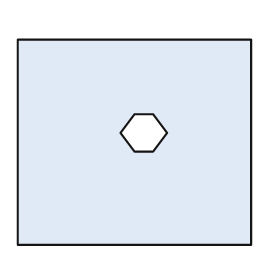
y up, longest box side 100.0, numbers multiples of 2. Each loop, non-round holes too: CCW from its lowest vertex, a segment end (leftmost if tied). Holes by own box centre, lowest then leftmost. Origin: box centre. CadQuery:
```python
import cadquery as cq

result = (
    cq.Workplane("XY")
    .moveTo(-50.0, -44.0)
    .lineTo(50.0, -44.0)
    .lineTo(50.0, 44.0)
    .lineTo(-50.0, 44.0)
    .close()
    .moveTo(0.0, -4.0)
    .lineTo(8.0, -4.0)
    .lineTo(14.0, 4.0)
    .lineTo(8.0, 12.0)
    .lineTo(0.0, 12.0)
    .lineTo(-6.0, 4.0)
    .close()
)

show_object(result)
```